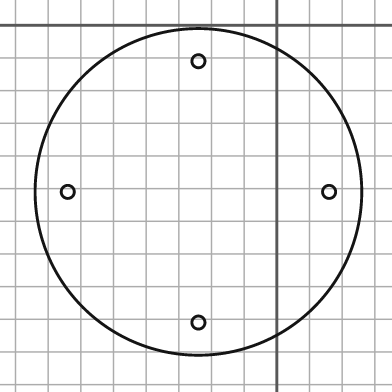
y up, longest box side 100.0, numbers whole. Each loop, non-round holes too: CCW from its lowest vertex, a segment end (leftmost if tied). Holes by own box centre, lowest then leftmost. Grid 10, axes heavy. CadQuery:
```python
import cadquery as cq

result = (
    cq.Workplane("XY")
    .moveTo(-24.0, -51.0)
    .circle(50.0)
    .moveTo(-24.0, -91.0)
    .circle(2.0)
    .moveTo(-64.0, -51.0)
    .circle(2.0)
    .moveTo(16.0, -51.0)
    .circle(2.0)
    .moveTo(-24.0, -11.0)
    .circle(2.0)
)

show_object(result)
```